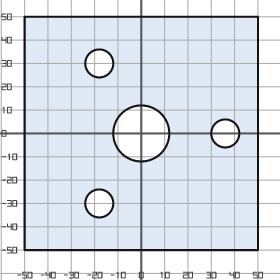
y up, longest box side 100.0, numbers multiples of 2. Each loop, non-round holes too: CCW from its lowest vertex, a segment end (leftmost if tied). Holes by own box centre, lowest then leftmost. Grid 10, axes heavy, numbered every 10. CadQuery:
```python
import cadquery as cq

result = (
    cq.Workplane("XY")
    .moveTo(-50.0, -50.0)
    .lineTo(50.0, -50.0)
    .lineTo(50.0, 50.0)
    .lineTo(-50.0, 50.0)
    .close()
    .moveTo(-18.0, -30.0)
    .circle(6.0)
    .moveTo(0.0, 0.0)
    .circle(12.0)
    .moveTo(36.0, 0.0)
    .circle(6.0)
    .moveTo(-18.0, 30.0)
    .circle(6.0)
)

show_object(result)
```